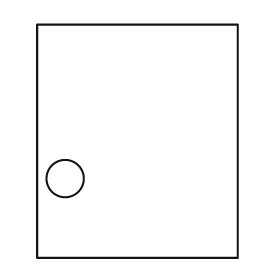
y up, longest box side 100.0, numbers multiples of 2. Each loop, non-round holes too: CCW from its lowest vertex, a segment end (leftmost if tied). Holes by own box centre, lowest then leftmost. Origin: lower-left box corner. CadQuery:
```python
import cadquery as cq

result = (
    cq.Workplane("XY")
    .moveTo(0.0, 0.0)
    .lineTo(86.0, 0.0)
    .lineTo(86.0, 100.0)
    .lineTo(0.0, 100.0)
    .close()
    .moveTo(12.0, 34.0)
    .circle(8.0)
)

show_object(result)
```